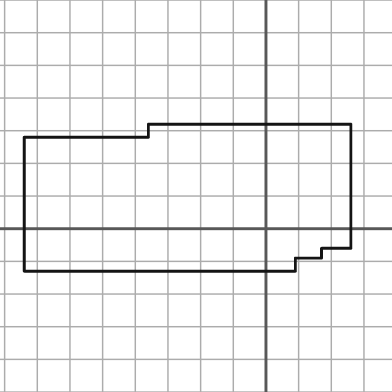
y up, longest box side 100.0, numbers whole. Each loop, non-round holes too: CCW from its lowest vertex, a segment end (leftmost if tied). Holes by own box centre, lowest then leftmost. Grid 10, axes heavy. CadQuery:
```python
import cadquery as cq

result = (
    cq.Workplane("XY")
    .moveTo(-74.0, -13.0)
    .lineTo(9.0, -13.0)
    .lineTo(9.0, -9.0)
    .lineTo(17.0, -9.0)
    .lineTo(17.0, -6.0)
    .lineTo(26.0, -6.0)
    .lineTo(26.0, 32.0)
    .lineTo(-36.0, 32.0)
    .lineTo(-36.0, 28.0)
    .lineTo(-74.0, 28.0)
    .close()
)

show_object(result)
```